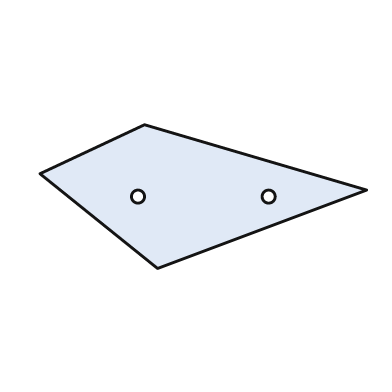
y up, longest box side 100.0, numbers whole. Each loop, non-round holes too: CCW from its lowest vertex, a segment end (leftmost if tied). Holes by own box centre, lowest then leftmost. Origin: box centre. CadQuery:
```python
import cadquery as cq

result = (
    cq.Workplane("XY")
    .moveTo(-14.0, -22.0)
    .lineTo(50.0, 2.0)
    .lineTo(-18.0, 22.0)
    .lineTo(-50.0, 7.0)
    .close()
    .moveTo(-20.0, 0.0)
    .circle(2.0)
    .moveTo(20.0, 0.0)
    .circle(2.0)
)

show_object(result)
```